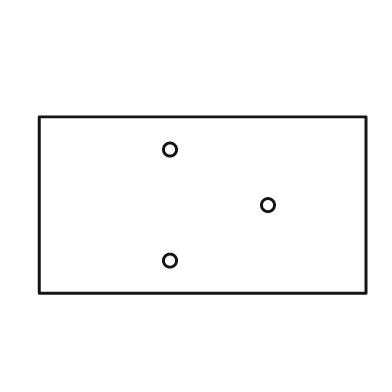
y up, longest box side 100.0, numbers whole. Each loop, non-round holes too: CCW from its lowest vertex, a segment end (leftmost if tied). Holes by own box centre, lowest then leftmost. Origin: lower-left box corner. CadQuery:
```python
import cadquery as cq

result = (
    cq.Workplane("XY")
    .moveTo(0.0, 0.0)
    .lineTo(100.0, 0.0)
    .lineTo(100.0, 54.0)
    .lineTo(0.0, 54.0)
    .close()
    .moveTo(40.0, 10.0)
    .circle(2.0)
    .moveTo(70.0, 27.0)
    .circle(2.0)
    .moveTo(40.0, 44.0)
    .circle(2.0)
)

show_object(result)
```